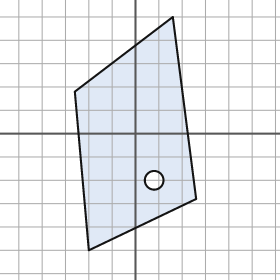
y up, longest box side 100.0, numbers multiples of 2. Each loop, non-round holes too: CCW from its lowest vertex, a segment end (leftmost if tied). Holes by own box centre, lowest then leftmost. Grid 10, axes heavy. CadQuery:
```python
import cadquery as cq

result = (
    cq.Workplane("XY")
    .moveTo(-20.0, -50.0)
    .lineTo(26.0, -28.0)
    .lineTo(16.0, 50.0)
    .lineTo(-26.0, 18.0)
    .close()
    .moveTo(8.0, -20.0)
    .circle(4.0)
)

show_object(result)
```